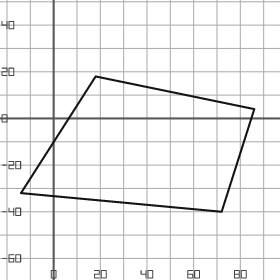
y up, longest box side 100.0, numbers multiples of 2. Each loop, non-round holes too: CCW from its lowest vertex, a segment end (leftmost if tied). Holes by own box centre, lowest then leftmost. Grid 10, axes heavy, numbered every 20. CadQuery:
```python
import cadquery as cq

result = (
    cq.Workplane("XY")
    .moveTo(72.0, -40.0)
    .lineTo(86.0, 4.0)
    .lineTo(18.0, 18.0)
    .lineTo(-14.0, -32.0)
    .close()
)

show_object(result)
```